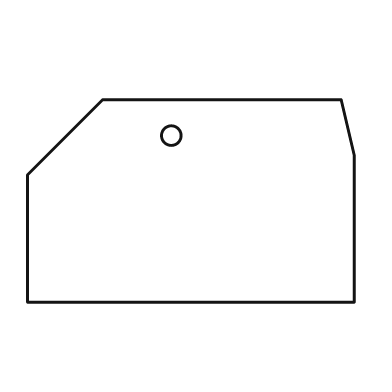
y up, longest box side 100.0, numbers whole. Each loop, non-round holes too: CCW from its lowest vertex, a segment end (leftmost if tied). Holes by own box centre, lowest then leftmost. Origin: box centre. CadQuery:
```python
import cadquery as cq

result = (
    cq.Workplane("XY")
    .moveTo(-50.0, -31.0)
    .lineTo(50.0, -31.0)
    .lineTo(50.0, 14.0)
    .lineTo(46.0, 31.0)
    .lineTo(-27.0, 31.0)
    .lineTo(-50.0, 8.0)
    .close()
    .moveTo(-6.0, 20.0)
    .circle(3.0)
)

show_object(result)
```